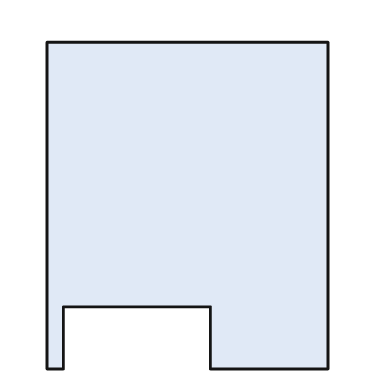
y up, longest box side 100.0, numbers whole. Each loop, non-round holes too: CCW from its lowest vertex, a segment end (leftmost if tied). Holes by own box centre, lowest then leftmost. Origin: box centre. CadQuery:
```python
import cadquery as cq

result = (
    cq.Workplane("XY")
    .moveTo(-43.0, -50.0)
    .lineTo(-38.0, -50.0)
    .lineTo(-38.0, -31.0)
    .lineTo(7.0, -31.0)
    .lineTo(7.0, -50.0)
    .lineTo(43.0, -50.0)
    .lineTo(43.0, 50.0)
    .lineTo(-43.0, 50.0)
    .close()
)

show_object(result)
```